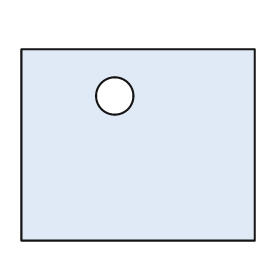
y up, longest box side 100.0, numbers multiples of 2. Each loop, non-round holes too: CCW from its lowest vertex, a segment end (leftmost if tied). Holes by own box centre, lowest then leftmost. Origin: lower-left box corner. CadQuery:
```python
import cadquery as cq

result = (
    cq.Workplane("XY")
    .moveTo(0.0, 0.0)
    .lineTo(100.0, 0.0)
    .lineTo(100.0, 82.0)
    .lineTo(0.0, 82.0)
    .close()
    .moveTo(40.0, 62.0)
    .circle(8.0)
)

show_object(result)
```